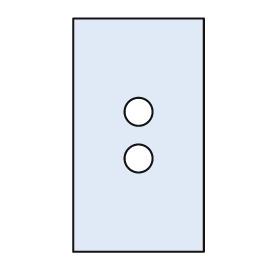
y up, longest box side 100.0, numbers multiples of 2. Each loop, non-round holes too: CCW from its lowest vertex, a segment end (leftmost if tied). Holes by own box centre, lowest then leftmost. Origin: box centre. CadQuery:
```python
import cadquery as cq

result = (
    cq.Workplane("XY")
    .moveTo(-28.0, -50.0)
    .lineTo(28.0, -50.0)
    .lineTo(28.0, 50.0)
    .lineTo(-28.0, 50.0)
    .close()
    .moveTo(0.0, -10.0)
    .circle(6.0)
    .moveTo(0.0, 10.0)
    .circle(6.0)
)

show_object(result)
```